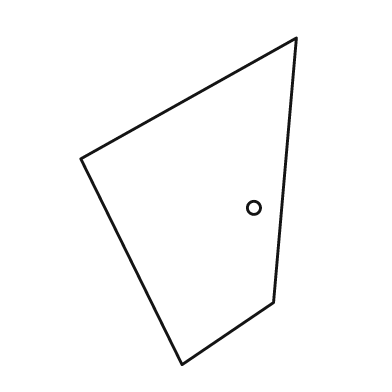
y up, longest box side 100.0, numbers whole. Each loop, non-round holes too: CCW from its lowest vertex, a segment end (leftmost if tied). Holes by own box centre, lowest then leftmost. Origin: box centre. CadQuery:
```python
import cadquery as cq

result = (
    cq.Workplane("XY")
    .moveTo(-2.0, -50.0)
    .lineTo(26.0, -31.0)
    .lineTo(33.0, 50.0)
    .lineTo(-33.0, 13.0)
    .close()
    .moveTo(20.0, -2.0)
    .circle(2.0)
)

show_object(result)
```